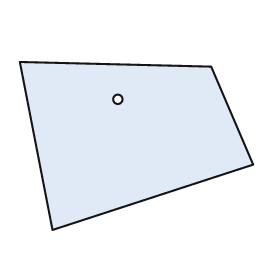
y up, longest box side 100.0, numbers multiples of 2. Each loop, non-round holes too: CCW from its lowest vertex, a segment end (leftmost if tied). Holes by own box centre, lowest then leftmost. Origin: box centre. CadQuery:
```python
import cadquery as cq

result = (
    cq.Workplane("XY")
    .moveTo(-36.0, -36.0)
    .lineTo(50.0, -8.0)
    .lineTo(32.0, 34.0)
    .lineTo(-50.0, 36.0)
    .close()
    .moveTo(-8.0, 20.0)
    .circle(2.0)
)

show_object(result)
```